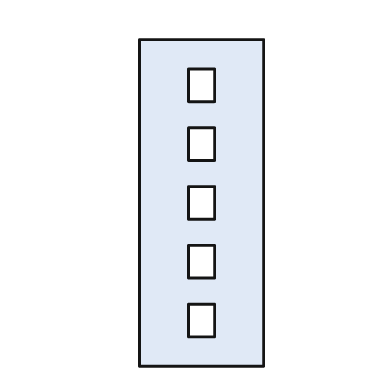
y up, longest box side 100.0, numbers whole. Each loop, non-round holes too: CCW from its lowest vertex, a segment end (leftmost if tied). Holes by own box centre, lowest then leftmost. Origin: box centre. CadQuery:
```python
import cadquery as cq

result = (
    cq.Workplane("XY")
    .moveTo(-19.0, -50.0)
    .lineTo(19.0, -50.0)
    .lineTo(19.0, 50.0)
    .lineTo(-19.0, 50.0)
    .close()
    .moveTo(-4.0, -41.0)
    .lineTo(4.0, -41.0)
    .lineTo(4.0, -31.0)
    .lineTo(-4.0, -31.0)
    .close()
    .moveTo(-4.0, -23.0)
    .lineTo(4.0, -23.0)
    .lineTo(4.0, -13.0)
    .lineTo(-4.0, -13.0)
    .close()
    .moveTo(-4.0, -5.0)
    .lineTo(4.0, -5.0)
    .lineTo(4.0, 5.0)
    .lineTo(-4.0, 5.0)
    .close()
    .moveTo(-4.0, 13.0)
    .lineTo(4.0, 13.0)
    .lineTo(4.0, 23.0)
    .lineTo(-4.0, 23.0)
    .close()
    .moveTo(-4.0, 31.0)
    .lineTo(4.0, 31.0)
    .lineTo(4.0, 41.0)
    .lineTo(-4.0, 41.0)
    .close()
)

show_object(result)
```